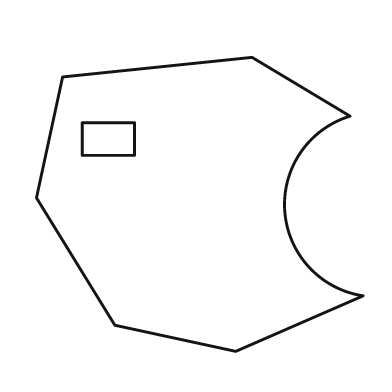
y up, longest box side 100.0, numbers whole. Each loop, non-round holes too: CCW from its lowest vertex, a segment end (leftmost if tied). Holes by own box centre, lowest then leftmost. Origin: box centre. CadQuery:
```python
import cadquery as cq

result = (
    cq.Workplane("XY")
    .moveTo(11.0, -45.0)
    .lineTo(50.0, -28.0)
    .threePointArc((26.0, -2.0), (46.0, 27.0))
    .lineTo(16.0, 45.0)
    .lineTo(-42.0, 39.0)
    .lineTo(-50.0, 2.0)
    .lineTo(-26.0, -37.0)
    .close()
    .moveTo(-36.0, 15.0)
    .lineTo(-20.0, 15.0)
    .lineTo(-20.0, 25.0)
    .lineTo(-36.0, 25.0)
    .close()
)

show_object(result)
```